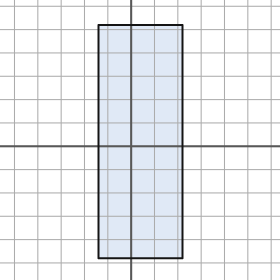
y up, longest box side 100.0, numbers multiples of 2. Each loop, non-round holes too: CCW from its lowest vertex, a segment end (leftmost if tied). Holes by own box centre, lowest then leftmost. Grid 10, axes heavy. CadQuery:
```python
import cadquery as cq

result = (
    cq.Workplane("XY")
    .moveTo(-14.0, -48.0)
    .lineTo(22.0, -48.0)
    .lineTo(22.0, 52.0)
    .lineTo(-14.0, 52.0)
    .close()
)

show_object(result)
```